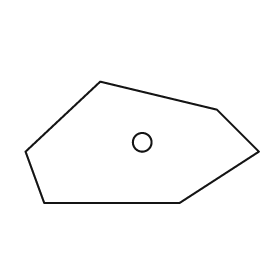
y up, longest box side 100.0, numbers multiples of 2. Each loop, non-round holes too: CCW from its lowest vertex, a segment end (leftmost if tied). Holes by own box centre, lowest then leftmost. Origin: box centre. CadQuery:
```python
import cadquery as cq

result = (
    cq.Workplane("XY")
    .moveTo(-42.0, -26.0)
    .lineTo(16.0, -26.0)
    .lineTo(50.0, -4.0)
    .lineTo(32.0, 14.0)
    .lineTo(-18.0, 26.0)
    .lineTo(-50.0, -4.0)
    .close()
    .moveTo(0.0, 0.0)
    .circle(4.0)
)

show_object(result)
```